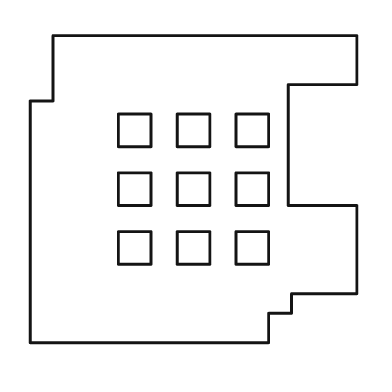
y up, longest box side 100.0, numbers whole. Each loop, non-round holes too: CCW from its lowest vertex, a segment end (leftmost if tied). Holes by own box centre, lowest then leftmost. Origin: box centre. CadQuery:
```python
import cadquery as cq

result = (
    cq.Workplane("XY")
    .moveTo(-50.0, -47.0)
    .lineTo(23.0, -47.0)
    .lineTo(23.0, -38.0)
    .lineTo(30.0, -38.0)
    .lineTo(30.0, -32.0)
    .lineTo(50.0, -32.0)
    .lineTo(50.0, -5.0)
    .lineTo(29.0, -5.0)
    .lineTo(29.0, 32.0)
    .lineTo(50.0, 32.0)
    .lineTo(50.0, 47.0)
    .lineTo(-43.0, 47.0)
    .lineTo(-43.0, 27.0)
    .lineTo(-50.0, 27.0)
    .close()
    .moveTo(-23.0, -23.0)
    .lineTo(-13.0, -23.0)
    .lineTo(-13.0, -13.0)
    .lineTo(-23.0, -13.0)
    .close()
    .moveTo(-5.0, -23.0)
    .lineTo(5.0, -23.0)
    .lineTo(5.0, -13.0)
    .lineTo(-5.0, -13.0)
    .close()
    .moveTo(13.0, -23.0)
    .lineTo(23.0, -23.0)
    .lineTo(23.0, -13.0)
    .lineTo(13.0, -13.0)
    .close()
    .moveTo(-23.0, -5.0)
    .lineTo(-13.0, -5.0)
    .lineTo(-13.0, 5.0)
    .lineTo(-23.0, 5.0)
    .close()
    .moveTo(-5.0, -5.0)
    .lineTo(5.0, -5.0)
    .lineTo(5.0, 5.0)
    .lineTo(-5.0, 5.0)
    .close()
    .moveTo(13.0, -5.0)
    .lineTo(23.0, -5.0)
    .lineTo(23.0, 5.0)
    .lineTo(13.0, 5.0)
    .close()
    .moveTo(-23.0, 13.0)
    .lineTo(-13.0, 13.0)
    .lineTo(-13.0, 23.0)
    .lineTo(-23.0, 23.0)
    .close()
    .moveTo(-5.0, 13.0)
    .lineTo(5.0, 13.0)
    .lineTo(5.0, 23.0)
    .lineTo(-5.0, 23.0)
    .close()
    .moveTo(13.0, 13.0)
    .lineTo(23.0, 13.0)
    .lineTo(23.0, 23.0)
    .lineTo(13.0, 23.0)
    .close()
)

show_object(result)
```